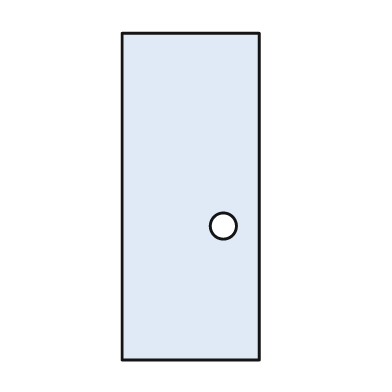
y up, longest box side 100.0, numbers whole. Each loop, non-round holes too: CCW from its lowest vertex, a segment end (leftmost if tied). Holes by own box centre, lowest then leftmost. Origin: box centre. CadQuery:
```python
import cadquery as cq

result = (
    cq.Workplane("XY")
    .moveTo(-21.0, -50.0)
    .lineTo(21.0, -50.0)
    .lineTo(21.0, 50.0)
    .lineTo(-21.0, 50.0)
    .close()
    .moveTo(10.0, -9.0)
    .circle(4.0)
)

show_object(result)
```